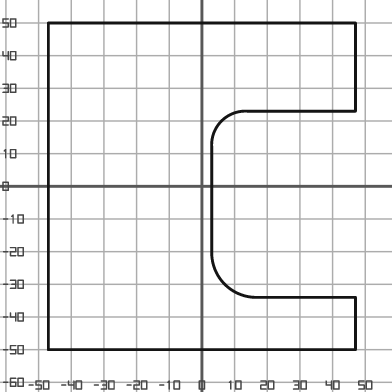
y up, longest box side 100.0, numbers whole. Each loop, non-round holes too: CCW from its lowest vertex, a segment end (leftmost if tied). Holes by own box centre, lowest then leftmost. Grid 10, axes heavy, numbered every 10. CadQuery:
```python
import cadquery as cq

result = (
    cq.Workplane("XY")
    .moveTo(-47.0, -50.0)
    .lineTo(47.0, -50.0)
    .lineTo(47.0, -34.0)
    .lineTo(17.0, -34.0)
    .threePointArc((7.0, -30.0), (3.0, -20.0))
    .lineTo(3.0, 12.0)
    .threePointArc((6.0, 20.0), (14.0, 23.0))
    .lineTo(47.0, 23.0)
    .lineTo(47.0, 50.0)
    .lineTo(-47.0, 50.0)
    .close()
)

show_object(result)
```